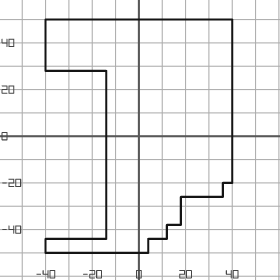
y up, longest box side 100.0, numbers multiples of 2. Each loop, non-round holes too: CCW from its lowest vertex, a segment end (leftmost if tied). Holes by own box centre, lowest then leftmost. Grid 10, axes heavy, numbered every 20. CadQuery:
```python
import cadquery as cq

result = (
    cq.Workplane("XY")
    .moveTo(-40.0, -50.0)
    .lineTo(4.0, -50.0)
    .lineTo(4.0, -44.0)
    .lineTo(12.0, -44.0)
    .lineTo(12.0, -38.0)
    .lineTo(18.0, -38.0)
    .lineTo(18.0, -26.0)
    .lineTo(36.0, -26.0)
    .lineTo(36.0, -20.0)
    .lineTo(40.0, -20.0)
    .lineTo(40.0, 50.0)
    .lineTo(-40.0, 50.0)
    .lineTo(-40.0, 28.0)
    .lineTo(-14.0, 28.0)
    .lineTo(-14.0, -44.0)
    .lineTo(-40.0, -44.0)
    .close()
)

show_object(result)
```